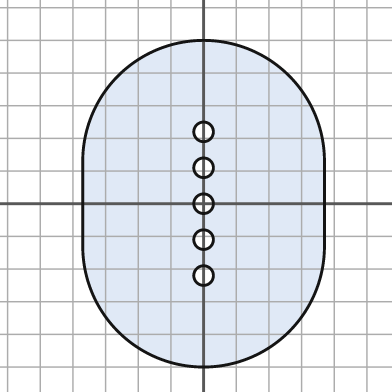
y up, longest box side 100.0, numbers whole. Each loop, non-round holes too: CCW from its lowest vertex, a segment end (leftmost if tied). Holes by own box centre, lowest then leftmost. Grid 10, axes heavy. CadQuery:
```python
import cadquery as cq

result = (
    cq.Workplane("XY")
    .moveTo(-37.0, -13.0)
    .threePointArc((0.0, -50.0), (37.0, -13.0))
    .lineTo(37.0, 13.0)
    .threePointArc((0.0, 50.0), (-37.0, 13.0))
    .close()
    .moveTo(0.0, -22.0)
    .circle(3.0)
    .moveTo(0.0, -11.0)
    .circle(3.0)
    .moveTo(0.0, 0.0)
    .circle(3.0)
    .moveTo(0.0, 11.0)
    .circle(3.0)
    .moveTo(0.0, 22.0)
    .circle(3.0)
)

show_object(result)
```